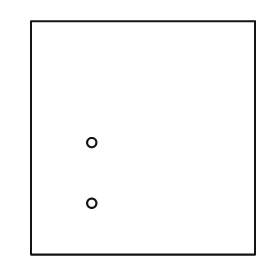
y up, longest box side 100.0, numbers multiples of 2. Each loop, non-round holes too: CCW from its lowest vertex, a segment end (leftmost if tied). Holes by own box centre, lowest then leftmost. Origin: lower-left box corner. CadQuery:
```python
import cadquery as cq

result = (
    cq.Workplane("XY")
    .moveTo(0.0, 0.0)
    .lineTo(96.0, 0.0)
    .lineTo(96.0, 100.0)
    .lineTo(0.0, 100.0)
    .close()
    .moveTo(26.0, 22.0)
    .circle(2.0)
    .moveTo(26.0, 48.0)
    .circle(2.0)
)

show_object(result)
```